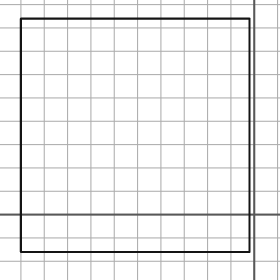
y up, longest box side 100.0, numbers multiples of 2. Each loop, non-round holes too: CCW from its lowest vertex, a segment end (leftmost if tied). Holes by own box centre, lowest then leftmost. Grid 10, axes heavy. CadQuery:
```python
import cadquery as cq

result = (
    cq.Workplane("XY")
    .moveTo(-100.0, -16.0)
    .lineTo(-2.0, -16.0)
    .lineTo(-2.0, 84.0)
    .lineTo(-100.0, 84.0)
    .close()
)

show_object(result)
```